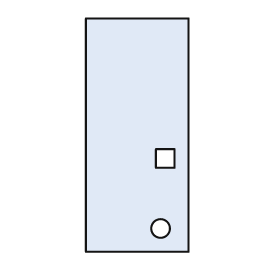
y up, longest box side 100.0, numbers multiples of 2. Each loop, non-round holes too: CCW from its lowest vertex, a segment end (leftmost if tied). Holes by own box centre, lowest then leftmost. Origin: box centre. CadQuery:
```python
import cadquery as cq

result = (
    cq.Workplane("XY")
    .moveTo(-22.0, -50.0)
    .lineTo(22.0, -50.0)
    .lineTo(22.0, 50.0)
    .lineTo(-22.0, 50.0)
    .close()
    .moveTo(10.0, -40.0)
    .circle(4.0)
    .moveTo(8.0, -14.0)
    .lineTo(16.0, -14.0)
    .lineTo(16.0, -6.0)
    .lineTo(8.0, -6.0)
    .close()
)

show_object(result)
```